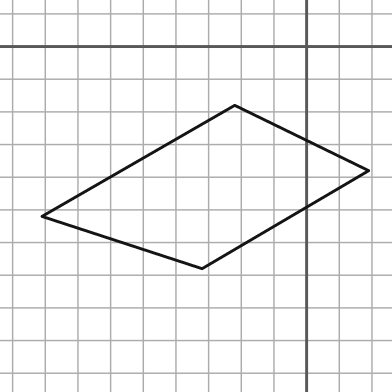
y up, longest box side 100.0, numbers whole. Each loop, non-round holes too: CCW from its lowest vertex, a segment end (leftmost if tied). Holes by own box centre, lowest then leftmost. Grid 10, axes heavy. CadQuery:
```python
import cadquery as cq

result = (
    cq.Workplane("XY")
    .moveTo(-32.0, -68.0)
    .lineTo(19.0, -38.0)
    .lineTo(-22.0, -18.0)
    .lineTo(-81.0, -52.0)
    .close()
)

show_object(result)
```